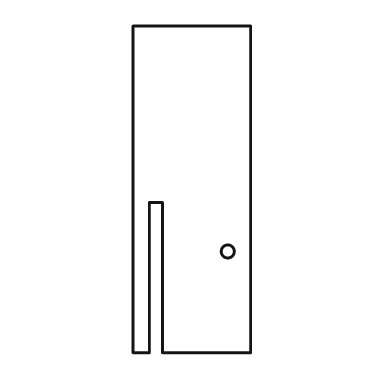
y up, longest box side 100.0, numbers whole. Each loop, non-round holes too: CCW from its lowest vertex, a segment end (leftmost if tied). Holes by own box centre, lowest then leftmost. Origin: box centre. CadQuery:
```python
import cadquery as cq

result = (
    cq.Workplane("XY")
    .moveTo(-18.0, -50.0)
    .lineTo(-13.0, -50.0)
    .lineTo(-13.0, -4.0)
    .lineTo(-9.0, -4.0)
    .lineTo(-9.0, -50.0)
    .lineTo(18.0, -50.0)
    .lineTo(18.0, 50.0)
    .lineTo(-18.0, 50.0)
    .close()
    .moveTo(11.0, -19.0)
    .circle(2.0)
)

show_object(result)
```